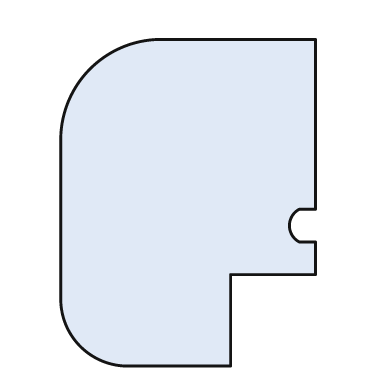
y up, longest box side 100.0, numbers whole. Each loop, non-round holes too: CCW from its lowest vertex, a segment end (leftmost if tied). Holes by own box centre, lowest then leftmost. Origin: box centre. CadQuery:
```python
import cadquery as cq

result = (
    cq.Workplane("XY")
    .moveTo(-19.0, -50.0)
    .lineTo(13.0, -50.0)
    .lineTo(13.0, -22.0)
    .lineTo(39.0, -22.0)
    .lineTo(39.0, -12.0)
    .lineTo(34.0, -12.0)
    .threePointArc((31.0, -7.0), (34.0, -2.0))
    .lineTo(39.0, -2.0)
    .lineTo(39.0, 50.0)
    .lineTo(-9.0, 50.0)
    .threePointArc((-30.0, 41.0), (-39.0, 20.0))
    .lineTo(-39.0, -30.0)
    .threePointArc((-33.0, -44.0), (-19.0, -50.0))
    .close()
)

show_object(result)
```